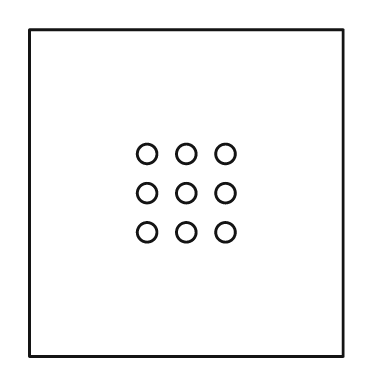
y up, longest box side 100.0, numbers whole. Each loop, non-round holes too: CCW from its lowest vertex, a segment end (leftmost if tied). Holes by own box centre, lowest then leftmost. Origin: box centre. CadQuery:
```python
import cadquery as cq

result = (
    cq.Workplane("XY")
    .moveTo(-48.0, -50.0)
    .lineTo(48.0, -50.0)
    .lineTo(48.0, 50.0)
    .lineTo(-48.0, 50.0)
    .close()
    .moveTo(-12.0, -12.0)
    .circle(3.0)
    .moveTo(0.0, -12.0)
    .circle(3.0)
    .moveTo(12.0, -12.0)
    .circle(3.0)
    .moveTo(-12.0, 0.0)
    .circle(3.0)
    .moveTo(0.0, 0.0)
    .circle(3.0)
    .moveTo(12.0, 0.0)
    .circle(3.0)
    .moveTo(-12.0, 12.0)
    .circle(3.0)
    .moveTo(0.0, 12.0)
    .circle(3.0)
    .moveTo(12.0, 12.0)
    .circle(3.0)
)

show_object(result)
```